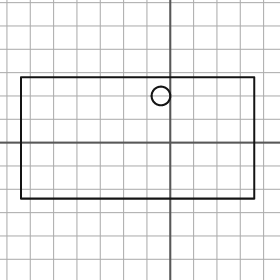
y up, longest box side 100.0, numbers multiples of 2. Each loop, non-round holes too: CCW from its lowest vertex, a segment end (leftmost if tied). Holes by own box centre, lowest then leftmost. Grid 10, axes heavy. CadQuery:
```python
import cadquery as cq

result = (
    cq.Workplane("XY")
    .moveTo(-64.0, -24.0)
    .lineTo(36.0, -24.0)
    .lineTo(36.0, 28.0)
    .lineTo(-64.0, 28.0)
    .close()
    .moveTo(-4.0, 20.0)
    .circle(4.0)
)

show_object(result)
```